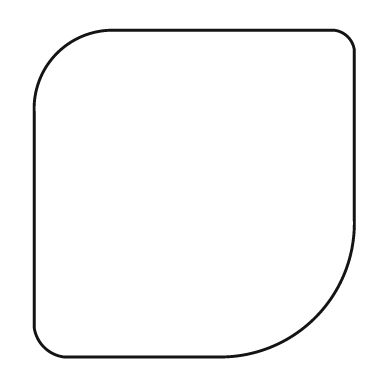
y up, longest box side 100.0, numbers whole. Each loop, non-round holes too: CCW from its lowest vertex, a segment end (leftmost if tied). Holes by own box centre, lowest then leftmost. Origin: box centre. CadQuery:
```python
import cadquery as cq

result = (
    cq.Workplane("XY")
    .moveTo(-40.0, -50.0)
    .lineTo(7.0, -50.0)
    .threePointArc((37.0, -38.0), (49.0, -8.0))
    .lineTo(49.0, 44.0)
    .threePointArc((47.0, 48.0), (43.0, 50.0))
    .lineTo(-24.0, 50.0)
    .threePointArc((-42.0, 43.0), (-49.0, 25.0))
    .lineTo(-49.0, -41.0)
    .threePointArc((-46.0, -47.0), (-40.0, -50.0))
    .close()
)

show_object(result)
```